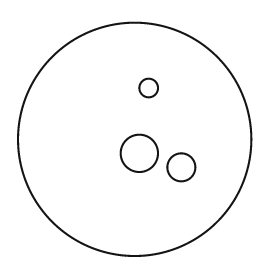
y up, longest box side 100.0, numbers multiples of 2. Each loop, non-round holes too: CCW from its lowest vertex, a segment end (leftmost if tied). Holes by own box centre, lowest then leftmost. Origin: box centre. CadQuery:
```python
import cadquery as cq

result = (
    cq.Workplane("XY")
    .moveTo(0.0, 0.0)
    .circle(50.0)
    .moveTo(20.0, -12.0)
    .circle(6.0)
    .moveTo(2.0, -6.0)
    .circle(8.0)
    .moveTo(6.0, 22.0)
    .circle(4.0)
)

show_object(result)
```